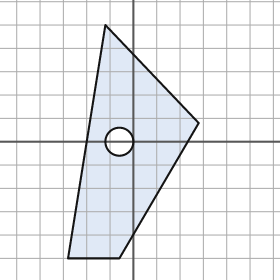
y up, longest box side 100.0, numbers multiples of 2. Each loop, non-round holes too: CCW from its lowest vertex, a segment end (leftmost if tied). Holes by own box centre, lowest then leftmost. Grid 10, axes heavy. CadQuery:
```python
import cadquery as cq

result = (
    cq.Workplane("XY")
    .moveTo(-28.0, -50.0)
    .lineTo(-6.0, -50.0)
    .lineTo(28.0, 8.0)
    .lineTo(-12.0, 50.0)
    .close()
    .moveTo(-6.0, 0.0)
    .circle(6.0)
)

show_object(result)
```